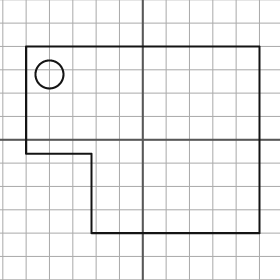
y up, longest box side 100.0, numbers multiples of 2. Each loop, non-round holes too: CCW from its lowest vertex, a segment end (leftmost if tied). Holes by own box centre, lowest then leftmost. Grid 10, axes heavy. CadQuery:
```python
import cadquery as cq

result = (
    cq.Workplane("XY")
    .moveTo(-22.0, -40.0)
    .lineTo(50.0, -40.0)
    .lineTo(50.0, 40.0)
    .lineTo(-50.0, 40.0)
    .lineTo(-50.0, -6.0)
    .lineTo(-22.0, -6.0)
    .close()
    .moveTo(-40.0, 28.0)
    .circle(6.0)
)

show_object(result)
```